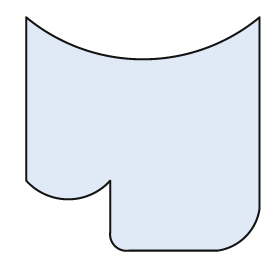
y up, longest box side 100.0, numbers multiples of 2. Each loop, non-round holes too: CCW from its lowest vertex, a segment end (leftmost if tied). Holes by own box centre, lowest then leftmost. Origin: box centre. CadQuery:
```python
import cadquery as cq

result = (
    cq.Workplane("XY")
    .moveTo(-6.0, -50.0)
    .lineTo(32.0, -50.0)
    .threePointArc((44.0, -44.0), (50.0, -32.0))
    .lineTo(50.0, 50.0)
    .threePointArc((0.0, 32.0), (-50.0, 50.0))
    .lineTo(-50.0, -20.0)
    .threePointArc((-32.0, -28.0), (-14.0, -20.0))
    .lineTo(-14.0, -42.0)
    .threePointArc((-12.0, -48.0), (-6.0, -50.0))
    .close()
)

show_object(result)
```